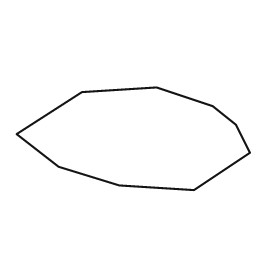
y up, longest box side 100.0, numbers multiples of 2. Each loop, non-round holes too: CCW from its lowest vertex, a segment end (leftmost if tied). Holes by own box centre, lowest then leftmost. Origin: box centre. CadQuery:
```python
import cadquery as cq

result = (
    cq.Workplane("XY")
    .moveTo(26.0, -22.0)
    .lineTo(50.0, -6.0)
    .lineTo(44.0, 6.0)
    .lineTo(34.0, 14.0)
    .lineTo(10.0, 22.0)
    .lineTo(-22.0, 20.0)
    .lineTo(-50.0, 2.0)
    .lineTo(-32.0, -12.0)
    .lineTo(-6.0, -20.0)
    .close()
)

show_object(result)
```